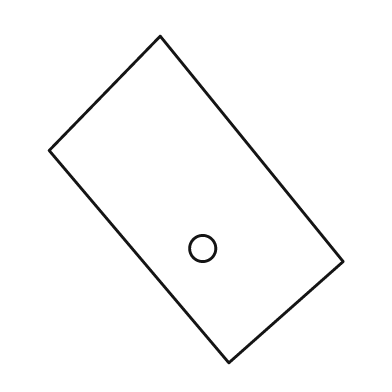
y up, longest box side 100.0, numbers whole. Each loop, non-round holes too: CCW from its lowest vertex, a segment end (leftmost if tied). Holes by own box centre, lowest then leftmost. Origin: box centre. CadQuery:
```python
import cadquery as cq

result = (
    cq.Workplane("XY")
    .moveTo(10.0, -50.0)
    .lineTo(45.0, -19.0)
    .lineTo(-11.0, 50.0)
    .lineTo(-45.0, 15.0)
    .close()
    .moveTo(2.0, -15.0)
    .circle(4.0)
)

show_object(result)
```